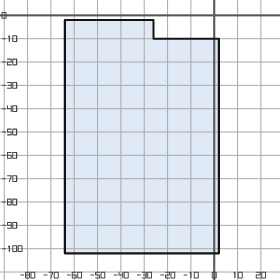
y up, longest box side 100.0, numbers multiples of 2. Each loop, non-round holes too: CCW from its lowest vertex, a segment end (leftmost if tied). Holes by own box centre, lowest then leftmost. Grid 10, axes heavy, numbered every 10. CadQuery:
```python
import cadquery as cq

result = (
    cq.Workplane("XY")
    .moveTo(-64.0, -102.0)
    .lineTo(2.0, -102.0)
    .lineTo(2.0, -10.0)
    .lineTo(-26.0, -10.0)
    .lineTo(-26.0, -2.0)
    .lineTo(-64.0, -2.0)
    .close()
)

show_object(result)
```